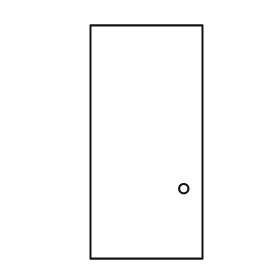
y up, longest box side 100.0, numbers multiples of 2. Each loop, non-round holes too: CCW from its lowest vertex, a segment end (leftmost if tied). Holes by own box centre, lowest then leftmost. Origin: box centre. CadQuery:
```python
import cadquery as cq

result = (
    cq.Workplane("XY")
    .moveTo(-24.0, -50.0)
    .lineTo(24.0, -50.0)
    .lineTo(24.0, 50.0)
    .lineTo(-24.0, 50.0)
    .close()
    .moveTo(16.0, -20.0)
    .circle(2.0)
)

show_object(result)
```